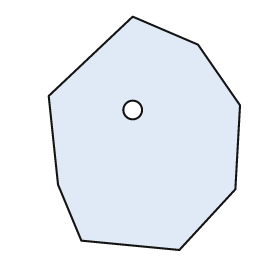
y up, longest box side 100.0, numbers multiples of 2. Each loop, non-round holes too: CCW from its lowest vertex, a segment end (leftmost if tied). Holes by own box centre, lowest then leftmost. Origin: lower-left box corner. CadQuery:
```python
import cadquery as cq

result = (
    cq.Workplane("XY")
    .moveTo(56.0, 0.0)
    .lineTo(80.0, 26.0)
    .lineTo(82.0, 62.0)
    .lineTo(64.0, 88.0)
    .lineTo(36.0, 100.0)
    .lineTo(0.0, 66.0)
    .lineTo(4.0, 28.0)
    .lineTo(14.0, 4.0)
    .close()
    .moveTo(36.0, 60.0)
    .circle(4.0)
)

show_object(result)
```